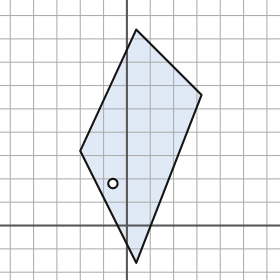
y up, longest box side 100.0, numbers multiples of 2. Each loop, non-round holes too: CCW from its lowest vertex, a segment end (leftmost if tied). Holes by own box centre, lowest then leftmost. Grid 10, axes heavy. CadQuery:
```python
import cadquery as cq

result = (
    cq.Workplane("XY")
    .moveTo(4.0, -16.0)
    .lineTo(32.0, 56.0)
    .lineTo(4.0, 84.0)
    .lineTo(-20.0, 32.0)
    .close()
    .moveTo(-6.0, 18.0)
    .circle(2.0)
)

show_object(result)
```